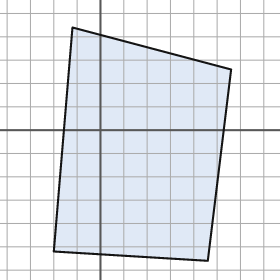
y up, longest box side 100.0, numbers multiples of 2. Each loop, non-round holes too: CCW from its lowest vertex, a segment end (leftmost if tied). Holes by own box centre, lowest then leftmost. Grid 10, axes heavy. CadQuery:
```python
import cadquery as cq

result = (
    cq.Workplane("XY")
    .moveTo(46.0, -56.0)
    .lineTo(56.0, 26.0)
    .lineTo(-12.0, 44.0)
    .lineTo(-20.0, -52.0)
    .close()
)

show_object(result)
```